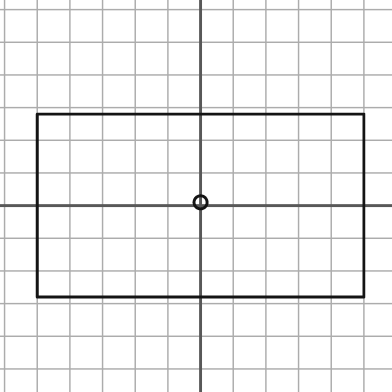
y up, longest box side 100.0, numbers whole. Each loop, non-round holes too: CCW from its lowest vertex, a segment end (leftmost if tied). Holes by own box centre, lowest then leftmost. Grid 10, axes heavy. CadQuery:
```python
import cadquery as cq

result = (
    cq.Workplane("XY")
    .moveTo(-50.0, -28.0)
    .lineTo(50.0, -28.0)
    .lineTo(50.0, 28.0)
    .lineTo(-50.0, 28.0)
    .close()
    .moveTo(0.0, 1.0)
    .circle(2.0)
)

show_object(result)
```